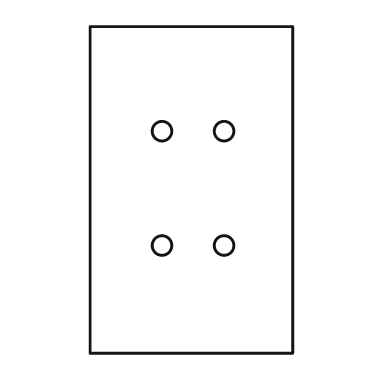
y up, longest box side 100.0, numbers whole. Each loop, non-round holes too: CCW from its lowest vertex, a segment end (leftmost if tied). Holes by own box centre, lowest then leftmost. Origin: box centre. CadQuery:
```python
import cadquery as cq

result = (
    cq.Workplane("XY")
    .moveTo(-31.0, -50.0)
    .lineTo(31.0, -50.0)
    .lineTo(31.0, 50.0)
    .lineTo(-31.0, 50.0)
    .close()
    .moveTo(-9.0, -17.0)
    .circle(3.0)
    .moveTo(10.0, -17.0)
    .circle(3.0)
    .moveTo(-9.0, 18.0)
    .circle(3.0)
    .moveTo(10.0, 18.0)
    .circle(3.0)
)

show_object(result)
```